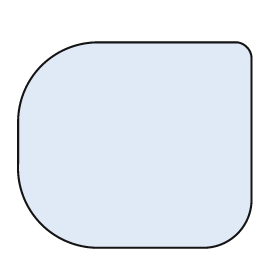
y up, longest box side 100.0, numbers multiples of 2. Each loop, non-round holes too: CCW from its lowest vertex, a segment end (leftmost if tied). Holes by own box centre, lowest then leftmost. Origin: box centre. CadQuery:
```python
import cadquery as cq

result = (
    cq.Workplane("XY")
    .moveTo(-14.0, -44.0)
    .lineTo(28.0, -44.0)
    .threePointArc((44.0, -38.0), (50.0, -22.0))
    .lineTo(50.0, 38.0)
    .threePointArc((48.0, 42.0), (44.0, 44.0))
    .lineTo(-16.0, 44.0)
    .threePointArc((-40.0, 34.0), (-50.0, 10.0))
    .lineTo(-50.0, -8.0)
    .threePointArc((-40.0, -34.0), (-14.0, -44.0))
    .close()
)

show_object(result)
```